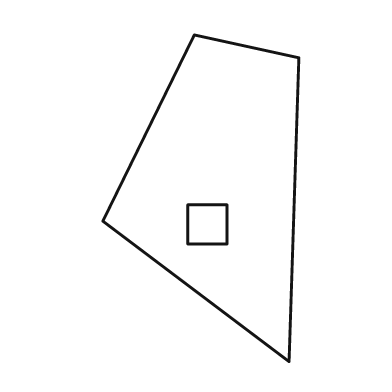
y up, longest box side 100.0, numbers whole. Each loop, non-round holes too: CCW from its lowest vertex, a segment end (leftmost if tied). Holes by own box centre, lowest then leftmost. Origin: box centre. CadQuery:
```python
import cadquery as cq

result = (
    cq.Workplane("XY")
    .moveTo(27.0, -50.0)
    .lineTo(30.0, 43.0)
    .lineTo(-2.0, 50.0)
    .lineTo(-30.0, -7.0)
    .close()
    .moveTo(-4.0, -14.0)
    .lineTo(8.0, -14.0)
    .lineTo(8.0, -2.0)
    .lineTo(-4.0, -2.0)
    .close()
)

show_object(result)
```